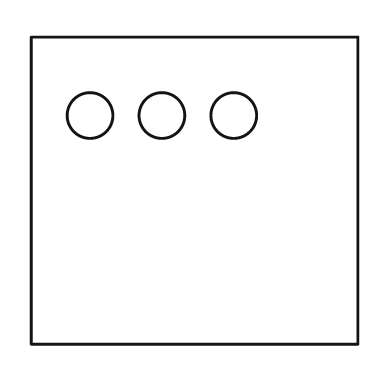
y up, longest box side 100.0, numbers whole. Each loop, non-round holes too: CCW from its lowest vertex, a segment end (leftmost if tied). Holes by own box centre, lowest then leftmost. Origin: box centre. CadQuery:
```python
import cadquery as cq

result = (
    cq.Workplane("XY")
    .moveTo(-50.0, -47.0)
    .lineTo(50.0, -47.0)
    .lineTo(50.0, 47.0)
    .lineTo(-50.0, 47.0)
    .close()
    .moveTo(-32.0, 23.0)
    .circle(7.0)
    .moveTo(-10.0, 23.0)
    .circle(7.0)
    .moveTo(12.0, 23.0)
    .circle(7.0)
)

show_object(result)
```